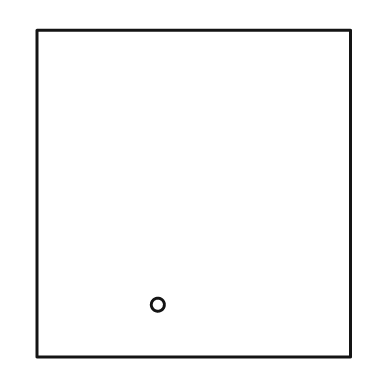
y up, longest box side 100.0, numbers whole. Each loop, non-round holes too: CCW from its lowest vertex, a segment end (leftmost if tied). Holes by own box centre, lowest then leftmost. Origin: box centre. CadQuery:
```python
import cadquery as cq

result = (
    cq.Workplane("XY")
    .moveTo(-48.0, -50.0)
    .lineTo(48.0, -50.0)
    .lineTo(48.0, 50.0)
    .lineTo(-48.0, 50.0)
    .close()
    .moveTo(-11.0, -34.0)
    .circle(2.0)
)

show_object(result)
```